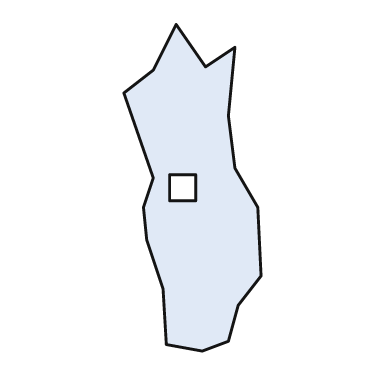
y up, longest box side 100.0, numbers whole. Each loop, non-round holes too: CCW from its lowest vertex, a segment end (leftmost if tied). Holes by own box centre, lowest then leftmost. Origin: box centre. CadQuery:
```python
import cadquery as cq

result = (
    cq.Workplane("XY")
    .moveTo(3.0, -50.0)
    .lineTo(11.0, -47.0)
    .lineTo(14.0, -36.0)
    .lineTo(21.0, -27.0)
    .lineTo(20.0, -6.0)
    .lineTo(13.0, 6.0)
    .lineTo(11.0, 22.0)
    .lineTo(13.0, 43.0)
    .lineTo(4.0, 37.0)
    .lineTo(-5.0, 50.0)
    .lineTo(-12.0, 36.0)
    .lineTo(-21.0, 29.0)
    .lineTo(-12.0, 3.0)
    .lineTo(-15.0, -6.0)
    .lineTo(-14.0, -16.0)
    .lineTo(-9.0, -31.0)
    .lineTo(-8.0, -48.0)
    .close()
    .moveTo(-7.0, -4.0)
    .lineTo(1.0, -4.0)
    .lineTo(1.0, 4.0)
    .lineTo(-7.0, 4.0)
    .close()
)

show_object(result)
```